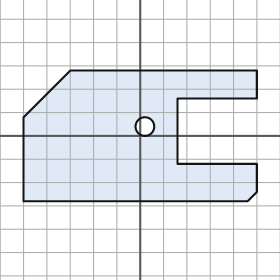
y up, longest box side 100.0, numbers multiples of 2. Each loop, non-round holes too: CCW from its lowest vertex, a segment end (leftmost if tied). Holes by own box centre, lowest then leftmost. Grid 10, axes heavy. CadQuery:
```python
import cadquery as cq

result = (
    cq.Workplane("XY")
    .moveTo(-50.0, -28.0)
    .lineTo(46.0, -28.0)
    .lineTo(50.0, -24.0)
    .lineTo(50.0, -12.0)
    .lineTo(16.0, -12.0)
    .lineTo(16.0, 16.0)
    .lineTo(50.0, 16.0)
    .lineTo(50.0, 28.0)
    .lineTo(-30.0, 28.0)
    .lineTo(-50.0, 8.0)
    .close()
    .moveTo(2.0, 4.0)
    .circle(4.0)
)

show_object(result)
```